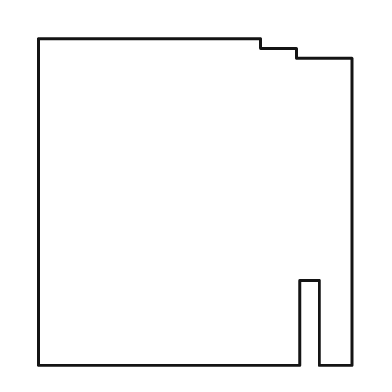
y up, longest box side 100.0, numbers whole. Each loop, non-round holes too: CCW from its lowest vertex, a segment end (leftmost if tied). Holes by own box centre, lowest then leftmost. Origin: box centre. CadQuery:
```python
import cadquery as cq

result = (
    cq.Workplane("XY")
    .moveTo(-48.0, -50.0)
    .lineTo(32.0, -50.0)
    .lineTo(32.0, -24.0)
    .lineTo(38.0, -24.0)
    .lineTo(38.0, -50.0)
    .lineTo(48.0, -50.0)
    .lineTo(48.0, 44.0)
    .lineTo(31.0, 44.0)
    .lineTo(31.0, 47.0)
    .lineTo(20.0, 47.0)
    .lineTo(20.0, 50.0)
    .lineTo(-48.0, 50.0)
    .close()
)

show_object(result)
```